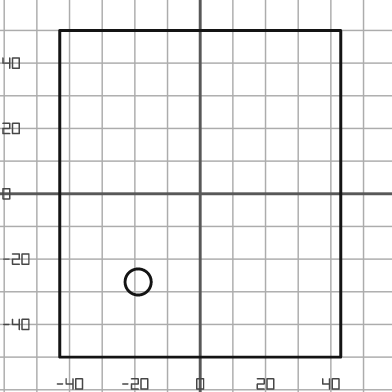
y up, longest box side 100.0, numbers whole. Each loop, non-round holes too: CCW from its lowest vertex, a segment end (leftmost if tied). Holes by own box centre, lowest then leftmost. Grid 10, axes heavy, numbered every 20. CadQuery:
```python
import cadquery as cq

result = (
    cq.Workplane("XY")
    .moveTo(-43.0, -50.0)
    .lineTo(43.0, -50.0)
    .lineTo(43.0, 50.0)
    .lineTo(-43.0, 50.0)
    .close()
    .moveTo(-19.0, -27.0)
    .circle(4.0)
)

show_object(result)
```